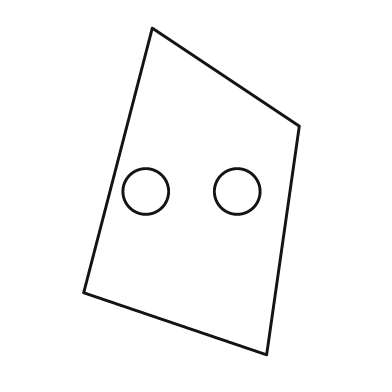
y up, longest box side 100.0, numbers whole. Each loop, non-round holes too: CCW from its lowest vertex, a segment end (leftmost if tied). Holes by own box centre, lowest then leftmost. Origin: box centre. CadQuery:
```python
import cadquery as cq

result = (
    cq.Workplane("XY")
    .moveTo(23.0, -50.0)
    .lineTo(33.0, 20.0)
    .lineTo(-12.0, 50.0)
    .lineTo(-33.0, -31.0)
    .close()
    .moveTo(-14.0, 0.0)
    .circle(7.0)
    .moveTo(14.0, 0.0)
    .circle(7.0)
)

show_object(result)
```